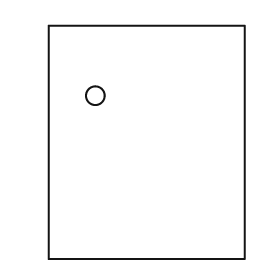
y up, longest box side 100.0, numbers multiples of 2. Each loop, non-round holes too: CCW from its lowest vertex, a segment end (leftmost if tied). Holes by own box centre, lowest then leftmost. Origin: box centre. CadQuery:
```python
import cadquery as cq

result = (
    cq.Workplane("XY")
    .moveTo(-42.0, -50.0)
    .lineTo(42.0, -50.0)
    .lineTo(42.0, 50.0)
    .lineTo(-42.0, 50.0)
    .close()
    .moveTo(-22.0, 20.0)
    .circle(4.0)
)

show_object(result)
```